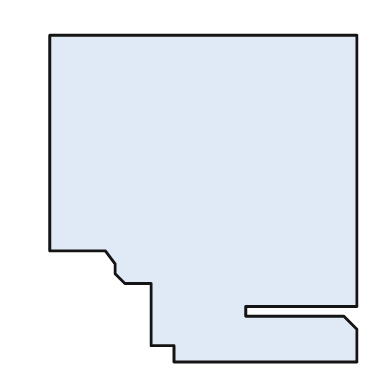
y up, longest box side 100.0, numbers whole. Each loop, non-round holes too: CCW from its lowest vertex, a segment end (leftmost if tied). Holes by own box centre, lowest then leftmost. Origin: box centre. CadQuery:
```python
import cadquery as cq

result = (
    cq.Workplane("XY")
    .moveTo(-9.0, -50.0)
    .lineTo(47.0, -50.0)
    .lineTo(47.0, -40.0)
    .lineTo(43.0, -36.0)
    .lineTo(13.0, -36.0)
    .lineTo(13.0, -33.0)
    .lineTo(47.0, -33.0)
    .lineTo(47.0, 50.0)
    .lineTo(-47.0, 50.0)
    .lineTo(-47.0, -16.0)
    .lineTo(-30.0, -16.0)
    .lineTo(-27.0, -20.0)
    .lineTo(-27.0, -23.0)
    .lineTo(-24.0, -26.0)
    .lineTo(-16.0, -26.0)
    .lineTo(-16.0, -45.0)
    .lineTo(-9.0, -45.0)
    .close()
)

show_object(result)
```